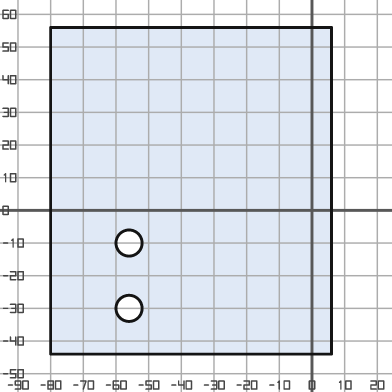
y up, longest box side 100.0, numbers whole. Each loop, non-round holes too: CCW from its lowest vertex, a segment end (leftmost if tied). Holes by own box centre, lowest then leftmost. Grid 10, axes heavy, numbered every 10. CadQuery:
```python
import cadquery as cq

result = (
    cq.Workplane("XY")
    .moveTo(-80.0, -44.0)
    .lineTo(6.0, -44.0)
    .lineTo(6.0, 56.0)
    .lineTo(-80.0, 56.0)
    .close()
    .moveTo(-56.0, -30.0)
    .circle(4.0)
    .moveTo(-56.0, -10.0)
    .circle(4.0)
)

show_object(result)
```